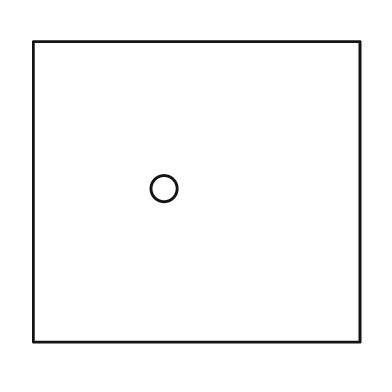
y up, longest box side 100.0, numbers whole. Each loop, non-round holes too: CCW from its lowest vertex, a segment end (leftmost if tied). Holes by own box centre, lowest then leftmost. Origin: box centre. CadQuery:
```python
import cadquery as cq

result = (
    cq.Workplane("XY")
    .moveTo(-50.0, -46.0)
    .lineTo(50.0, -46.0)
    .lineTo(50.0, 46.0)
    .lineTo(-50.0, 46.0)
    .close()
    .moveTo(-10.0, 1.0)
    .circle(4.0)
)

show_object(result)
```